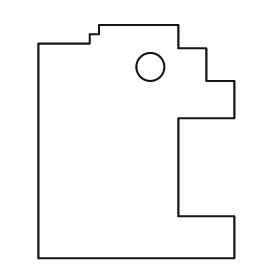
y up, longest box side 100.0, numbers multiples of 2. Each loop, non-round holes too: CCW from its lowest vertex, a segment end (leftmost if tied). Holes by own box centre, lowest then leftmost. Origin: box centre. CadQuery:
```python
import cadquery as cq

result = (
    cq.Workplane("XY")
    .moveTo(-42.0, -50.0)
    .lineTo(42.0, -50.0)
    .lineTo(42.0, -32.0)
    .lineTo(18.0, -32.0)
    .lineTo(18.0, 10.0)
    .lineTo(42.0, 10.0)
    .lineTo(42.0, 26.0)
    .lineTo(30.0, 26.0)
    .lineTo(30.0, 40.0)
    .lineTo(18.0, 40.0)
    .lineTo(18.0, 50.0)
    .lineTo(-16.0, 50.0)
    .lineTo(-16.0, 46.0)
    .lineTo(-20.0, 46.0)
    .lineTo(-20.0, 42.0)
    .lineTo(-42.0, 42.0)
    .close()
    .moveTo(6.0, 32.0)
    .circle(6.0)
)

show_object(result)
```